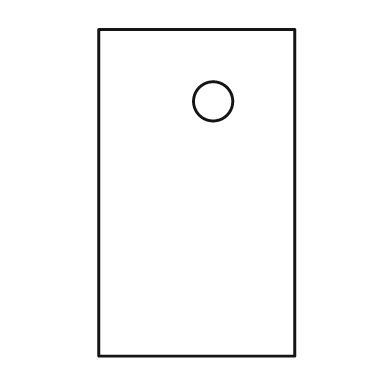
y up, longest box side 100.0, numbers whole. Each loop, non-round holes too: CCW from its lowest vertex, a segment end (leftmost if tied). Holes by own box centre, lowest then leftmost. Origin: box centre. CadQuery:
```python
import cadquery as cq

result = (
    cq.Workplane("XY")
    .moveTo(-30.0, -50.0)
    .lineTo(30.0, -50.0)
    .lineTo(30.0, 50.0)
    .lineTo(-30.0, 50.0)
    .close()
    .moveTo(5.0, 28.0)
    .circle(6.0)
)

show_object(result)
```